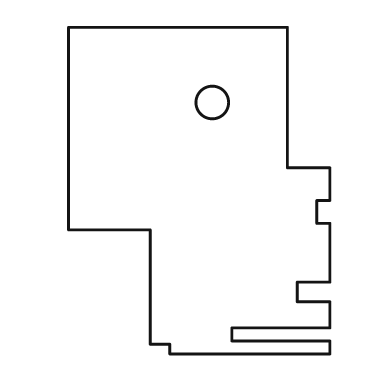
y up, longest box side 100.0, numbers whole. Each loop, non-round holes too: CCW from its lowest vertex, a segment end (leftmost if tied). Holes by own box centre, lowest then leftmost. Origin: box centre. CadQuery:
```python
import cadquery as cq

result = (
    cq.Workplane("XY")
    .moveTo(-9.0, -50.0)
    .lineTo(40.0, -50.0)
    .lineTo(40.0, -46.0)
    .lineTo(10.0, -46.0)
    .lineTo(10.0, -42.0)
    .lineTo(40.0, -42.0)
    .lineTo(40.0, -34.0)
    .lineTo(30.0, -34.0)
    .lineTo(30.0, -28.0)
    .lineTo(40.0, -28.0)
    .lineTo(40.0, -10.0)
    .lineTo(36.0, -10.0)
    .lineTo(36.0, -3.0)
    .lineTo(40.0, -3.0)
    .lineTo(40.0, 7.0)
    .lineTo(27.0, 7.0)
    .lineTo(27.0, 50.0)
    .lineTo(-40.0, 50.0)
    .lineTo(-40.0, -12.0)
    .lineTo(-15.0, -12.0)
    .lineTo(-15.0, -47.0)
    .lineTo(-9.0, -47.0)
    .close()
    .moveTo(4.0, 27.0)
    .circle(5.0)
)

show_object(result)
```